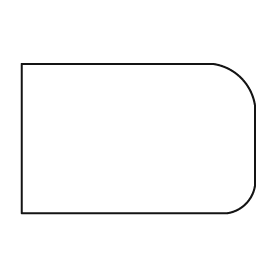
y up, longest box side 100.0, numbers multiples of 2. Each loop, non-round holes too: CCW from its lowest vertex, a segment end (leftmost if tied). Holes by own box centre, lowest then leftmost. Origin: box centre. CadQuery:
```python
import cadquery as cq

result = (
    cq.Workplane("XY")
    .moveTo(-50.0, -32.0)
    .lineTo(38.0, -32.0)
    .threePointArc((46.0, -28.0), (50.0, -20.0))
    .lineTo(50.0, 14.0)
    .threePointArc((44.0, 26.0), (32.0, 32.0))
    .lineTo(-50.0, 32.0)
    .close()
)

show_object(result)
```